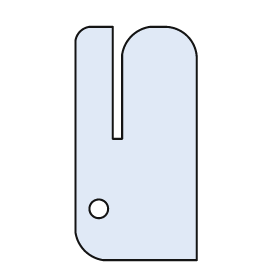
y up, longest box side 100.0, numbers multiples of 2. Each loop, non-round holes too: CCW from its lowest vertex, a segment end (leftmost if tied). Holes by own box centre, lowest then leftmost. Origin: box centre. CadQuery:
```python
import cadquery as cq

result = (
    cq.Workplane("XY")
    .moveTo(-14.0, -50.0)
    .lineTo(26.0, -50.0)
    .lineTo(26.0, 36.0)
    .threePointArc((22.0, 46.0), (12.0, 50.0))
    .lineTo(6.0, 50.0)
    .threePointArc((-2.0, 46.0), (-6.0, 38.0))
    .lineTo(-6.0, 2.0)
    .lineTo(-10.0, 2.0)
    .lineTo(-10.0, 50.0)
    .lineTo(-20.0, 50.0)
    .threePointArc((-24.0, 48.0), (-26.0, 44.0))
    .lineTo(-26.0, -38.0)
    .threePointArc((-22.0, -46.0), (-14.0, -50.0))
    .close()
    .moveTo(-16.0, -28.0)
    .circle(4.0)
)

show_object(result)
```